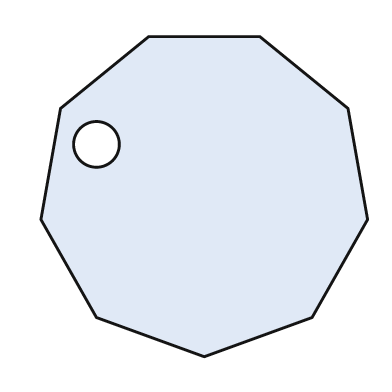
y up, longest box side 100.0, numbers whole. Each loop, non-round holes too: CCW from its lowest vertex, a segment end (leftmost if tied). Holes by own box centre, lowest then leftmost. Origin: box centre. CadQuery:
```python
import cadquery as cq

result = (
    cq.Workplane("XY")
    .moveTo(0.0, -49.0)
    .lineTo(33.0, -37.0)
    .lineTo(50.0, -7.0)
    .lineTo(44.0, 27.0)
    .lineTo(17.0, 49.0)
    .lineTo(-17.0, 49.0)
    .lineTo(-44.0, 27.0)
    .lineTo(-50.0, -7.0)
    .lineTo(-33.0, -37.0)
    .close()
    .moveTo(-33.0, 16.0)
    .circle(7.0)
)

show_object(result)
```